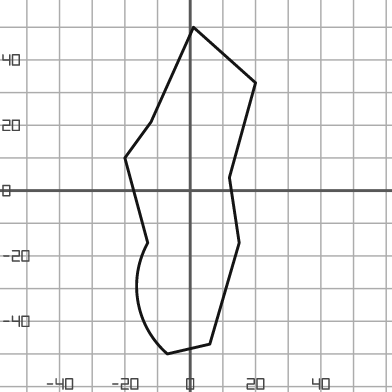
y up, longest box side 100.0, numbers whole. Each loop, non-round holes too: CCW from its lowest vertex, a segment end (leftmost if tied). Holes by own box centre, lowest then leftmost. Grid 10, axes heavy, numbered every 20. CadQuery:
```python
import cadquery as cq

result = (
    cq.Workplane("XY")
    .moveTo(-7.0, -50.0)
    .lineTo(6.0, -47.0)
    .lineTo(15.0, -16.0)
    .lineTo(12.0, 4.0)
    .lineTo(20.0, 33.0)
    .lineTo(1.0, 50.0)
    .lineTo(-12.0, 21.0)
    .lineTo(-20.0, 10.0)
    .lineTo(-13.0, -16.0)
    .threePointArc((-16.0, -34.0), (-7.0, -50.0))
    .close()
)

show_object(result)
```